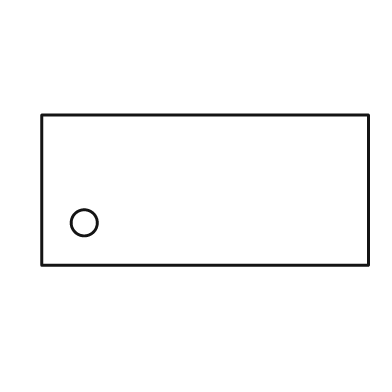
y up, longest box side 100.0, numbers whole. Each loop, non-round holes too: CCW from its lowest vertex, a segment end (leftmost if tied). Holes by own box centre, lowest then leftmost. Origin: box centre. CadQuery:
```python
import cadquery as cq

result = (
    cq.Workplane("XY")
    .moveTo(-50.0, -23.0)
    .lineTo(50.0, -23.0)
    .lineTo(50.0, 23.0)
    .lineTo(-50.0, 23.0)
    .close()
    .moveTo(-37.0, -10.0)
    .circle(4.0)
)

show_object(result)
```